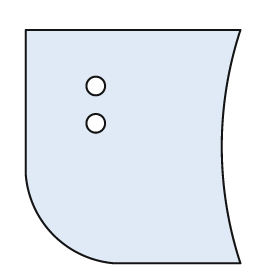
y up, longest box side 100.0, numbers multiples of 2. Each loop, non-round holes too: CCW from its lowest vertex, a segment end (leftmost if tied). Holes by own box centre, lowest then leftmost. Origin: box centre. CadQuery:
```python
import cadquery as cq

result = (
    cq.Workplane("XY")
    .moveTo(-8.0, -50.0)
    .lineTo(46.0, -50.0)
    .threePointArc((38.0, 0.0), (46.0, 50.0))
    .lineTo(-46.0, 50.0)
    .lineTo(-46.0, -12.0)
    .threePointArc((-34.0, -38.0), (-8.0, -50.0))
    .close()
    .moveTo(-16.0, 10.0)
    .circle(4.0)
    .moveTo(-16.0, 26.0)
    .circle(4.0)
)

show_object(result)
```